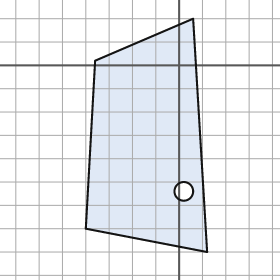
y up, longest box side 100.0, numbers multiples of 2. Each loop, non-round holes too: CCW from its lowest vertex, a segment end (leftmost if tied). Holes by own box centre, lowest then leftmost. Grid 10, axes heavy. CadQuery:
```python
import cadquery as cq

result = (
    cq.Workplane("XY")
    .moveTo(12.0, -80.0)
    .lineTo(6.0, 20.0)
    .lineTo(-36.0, 2.0)
    .lineTo(-40.0, -70.0)
    .close()
    .moveTo(2.0, -54.0)
    .circle(4.0)
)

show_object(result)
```